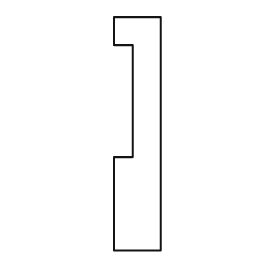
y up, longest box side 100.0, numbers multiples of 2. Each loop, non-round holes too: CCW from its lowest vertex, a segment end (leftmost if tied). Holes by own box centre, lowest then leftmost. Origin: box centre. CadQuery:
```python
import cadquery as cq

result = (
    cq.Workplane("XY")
    .moveTo(-10.0, -50.0)
    .lineTo(10.0, -50.0)
    .lineTo(10.0, 50.0)
    .lineTo(-10.0, 50.0)
    .lineTo(-10.0, 38.0)
    .lineTo(-2.0, 38.0)
    .lineTo(-2.0, -10.0)
    .lineTo(-10.0, -10.0)
    .close()
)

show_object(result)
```